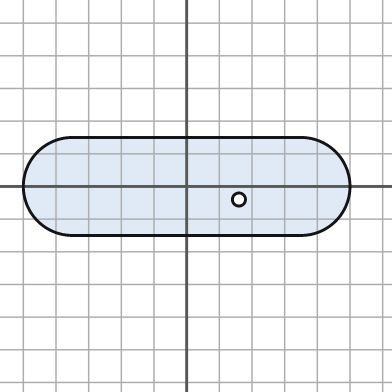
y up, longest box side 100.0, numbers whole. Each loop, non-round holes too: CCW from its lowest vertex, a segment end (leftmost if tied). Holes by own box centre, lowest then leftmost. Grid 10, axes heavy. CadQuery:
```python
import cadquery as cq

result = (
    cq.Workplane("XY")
    .moveTo(-35.0, -15.0)
    .lineTo(35.0, -15.0)
    .threePointArc((50.0, 0.0), (35.0, 15.0))
    .lineTo(-35.0, 15.0)
    .threePointArc((-50.0, 0.0), (-35.0, -15.0))
    .close()
    .moveTo(16.0, -4.0)
    .circle(2.0)
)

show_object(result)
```